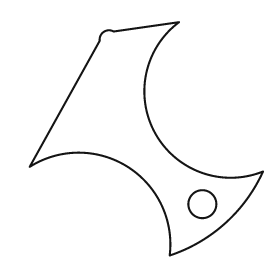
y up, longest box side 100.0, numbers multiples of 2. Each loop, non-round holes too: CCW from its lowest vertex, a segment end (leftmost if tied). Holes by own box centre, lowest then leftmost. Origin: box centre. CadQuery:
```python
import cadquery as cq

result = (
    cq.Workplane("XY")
    .moveTo(10.0, -50.0)
    .threePointArc((34.0, -36.0), (50.0, -14.0))
    .threePointArc((4.0, 2.0), (14.0, 50.0))
    .lineTo(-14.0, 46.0)
    .threePointArc((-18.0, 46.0), (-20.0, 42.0))
    .lineTo(-50.0, -12.0)
    .threePointArc((-8.0, -12.0), (10.0, -50.0))
    .close()
    .moveTo(24.0, -28.0)
    .circle(6.0)
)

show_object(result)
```